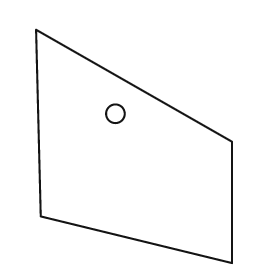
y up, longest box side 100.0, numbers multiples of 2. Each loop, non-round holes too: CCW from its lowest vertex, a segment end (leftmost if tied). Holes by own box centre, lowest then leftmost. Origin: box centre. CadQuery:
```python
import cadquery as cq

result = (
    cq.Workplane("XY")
    .moveTo(42.0, -50.0)
    .lineTo(42.0, 2.0)
    .lineTo(-42.0, 50.0)
    .lineTo(-40.0, -30.0)
    .close()
    .moveTo(-8.0, 14.0)
    .circle(4.0)
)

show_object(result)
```